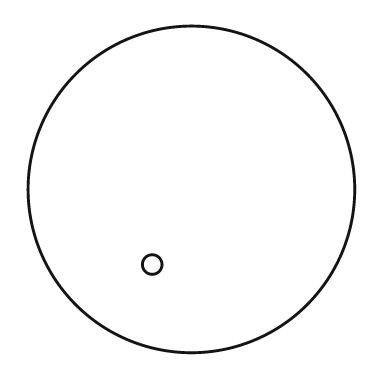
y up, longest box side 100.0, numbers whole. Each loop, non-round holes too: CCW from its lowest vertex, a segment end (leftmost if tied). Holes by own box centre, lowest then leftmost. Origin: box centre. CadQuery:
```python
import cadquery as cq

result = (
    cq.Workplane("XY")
    .moveTo(0.0, 0.0)
    .circle(50.0)
    .moveTo(-12.0, -23.0)
    .circle(3.0)
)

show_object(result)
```